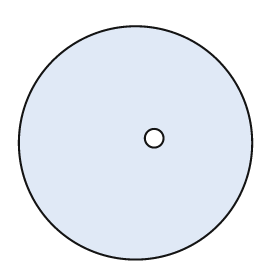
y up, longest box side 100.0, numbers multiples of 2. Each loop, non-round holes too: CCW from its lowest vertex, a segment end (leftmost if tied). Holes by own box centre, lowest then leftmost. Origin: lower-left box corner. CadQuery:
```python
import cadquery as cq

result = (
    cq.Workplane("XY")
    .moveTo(50.0, 50.0)
    .circle(50.0)
    .moveTo(58.0, 52.0)
    .circle(4.0)
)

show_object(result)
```